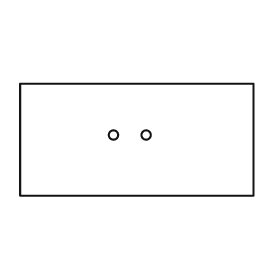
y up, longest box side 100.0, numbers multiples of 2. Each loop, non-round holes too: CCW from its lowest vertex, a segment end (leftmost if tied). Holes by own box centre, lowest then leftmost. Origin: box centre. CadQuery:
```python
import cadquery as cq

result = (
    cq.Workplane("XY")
    .moveTo(-50.0, -24.0)
    .lineTo(50.0, -24.0)
    .lineTo(50.0, 24.0)
    .lineTo(-50.0, 24.0)
    .close()
    .moveTo(-10.0, 2.0)
    .circle(2.0)
    .moveTo(4.0, 2.0)
    .circle(2.0)
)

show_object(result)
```